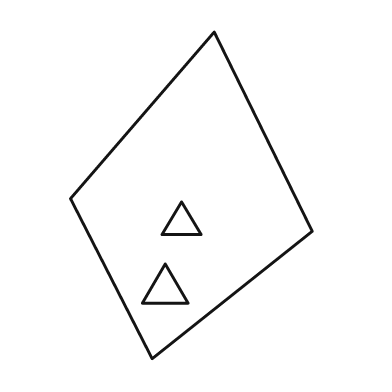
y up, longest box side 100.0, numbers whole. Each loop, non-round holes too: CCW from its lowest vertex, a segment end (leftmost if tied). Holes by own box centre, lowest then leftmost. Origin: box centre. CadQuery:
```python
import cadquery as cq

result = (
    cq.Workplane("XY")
    .moveTo(-12.0, -50.0)
    .lineTo(37.0, -11.0)
    .lineTo(7.0, 50.0)
    .lineTo(-37.0, -1.0)
    .close()
    .moveTo(-15.0, -33.0)
    .lineTo(-1.0, -33.0)
    .lineTo(-8.0, -21.0)
    .close()
    .moveTo(-9.0, -12.0)
    .lineTo(3.0, -12.0)
    .lineTo(-3.0, -2.0)
    .close()
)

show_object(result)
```